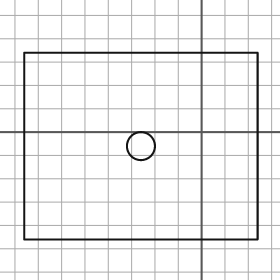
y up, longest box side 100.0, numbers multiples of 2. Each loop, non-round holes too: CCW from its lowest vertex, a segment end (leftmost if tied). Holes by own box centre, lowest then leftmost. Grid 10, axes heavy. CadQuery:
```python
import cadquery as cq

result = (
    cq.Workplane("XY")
    .moveTo(-76.0, -46.0)
    .lineTo(24.0, -46.0)
    .lineTo(24.0, 34.0)
    .lineTo(-76.0, 34.0)
    .close()
    .moveTo(-26.0, -6.0)
    .circle(6.0)
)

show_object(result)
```